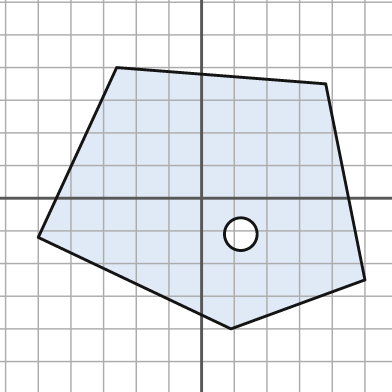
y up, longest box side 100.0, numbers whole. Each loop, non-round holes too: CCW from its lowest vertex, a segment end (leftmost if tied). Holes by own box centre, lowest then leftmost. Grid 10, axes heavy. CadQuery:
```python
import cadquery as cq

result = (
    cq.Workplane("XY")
    .moveTo(9.0, -40.0)
    .lineTo(50.0, -25.0)
    .lineTo(38.0, 35.0)
    .lineTo(-26.0, 40.0)
    .lineTo(-50.0, -12.0)
    .close()
    .moveTo(12.0, -11.0)
    .circle(5.0)
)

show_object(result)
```